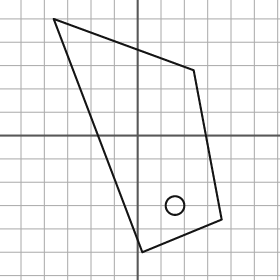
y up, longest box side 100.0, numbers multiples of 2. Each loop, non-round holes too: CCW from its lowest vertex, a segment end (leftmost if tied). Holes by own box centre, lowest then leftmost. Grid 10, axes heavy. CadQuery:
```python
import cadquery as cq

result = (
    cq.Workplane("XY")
    .moveTo(2.0, -50.0)
    .lineTo(36.0, -36.0)
    .lineTo(24.0, 28.0)
    .lineTo(-36.0, 50.0)
    .close()
    .moveTo(16.0, -30.0)
    .circle(4.0)
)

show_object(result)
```